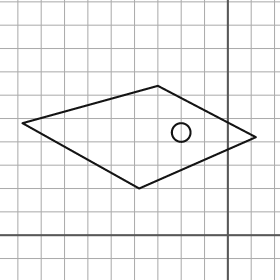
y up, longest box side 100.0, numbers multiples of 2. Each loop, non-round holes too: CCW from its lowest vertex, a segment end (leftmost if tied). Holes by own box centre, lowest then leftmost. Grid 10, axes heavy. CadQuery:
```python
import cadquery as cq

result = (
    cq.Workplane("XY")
    .moveTo(-38.0, 20.0)
    .lineTo(12.0, 42.0)
    .lineTo(-30.0, 64.0)
    .lineTo(-88.0, 48.0)
    .close()
    .moveTo(-20.0, 44.0)
    .circle(4.0)
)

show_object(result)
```